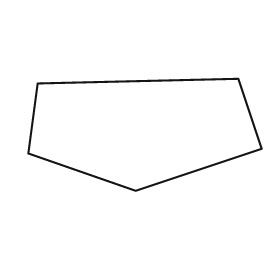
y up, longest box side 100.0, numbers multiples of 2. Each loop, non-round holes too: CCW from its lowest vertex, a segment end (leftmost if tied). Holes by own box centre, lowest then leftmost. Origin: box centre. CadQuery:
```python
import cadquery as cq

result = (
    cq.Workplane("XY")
    .moveTo(-4.0, -24.0)
    .lineTo(50.0, -6.0)
    .lineTo(40.0, 24.0)
    .lineTo(-46.0, 22.0)
    .lineTo(-50.0, -8.0)
    .close()
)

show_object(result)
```